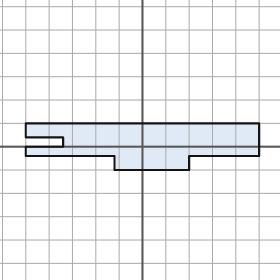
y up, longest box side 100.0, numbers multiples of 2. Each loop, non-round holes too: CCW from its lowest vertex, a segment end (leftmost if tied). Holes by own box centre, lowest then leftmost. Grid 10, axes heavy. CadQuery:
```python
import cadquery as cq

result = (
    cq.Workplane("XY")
    .moveTo(-12.0, -10.0)
    .lineTo(20.0, -10.0)
    .lineTo(20.0, -4.0)
    .lineTo(50.0, -4.0)
    .lineTo(50.0, 10.0)
    .lineTo(-50.0, 10.0)
    .lineTo(-50.0, 4.0)
    .lineTo(-34.0, 4.0)
    .lineTo(-34.0, 0.0)
    .lineTo(-50.0, 0.0)
    .lineTo(-50.0, -4.0)
    .lineTo(-12.0, -4.0)
    .close()
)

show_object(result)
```